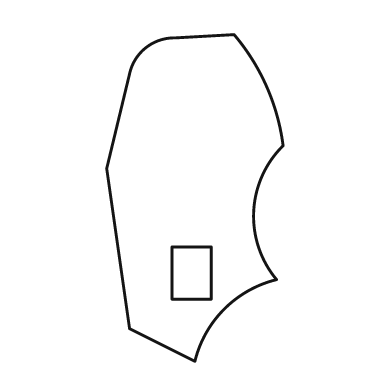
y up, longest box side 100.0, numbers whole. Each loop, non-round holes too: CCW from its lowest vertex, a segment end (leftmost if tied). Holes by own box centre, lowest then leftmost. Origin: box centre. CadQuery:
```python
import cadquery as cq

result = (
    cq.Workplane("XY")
    .moveTo(0.0, -50.0)
    .threePointArc((9.0, -34.0), (25.0, -25.0))
    .threePointArc((18.0, -4.0), (27.0, 16.0))
    .threePointArc((22.0, 34.0), (12.0, 50.0))
    .lineTo(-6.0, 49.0)
    .threePointArc((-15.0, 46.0), (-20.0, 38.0))
    .lineTo(-27.0, 9.0)
    .lineTo(-20.0, -40.0)
    .close()
    .moveTo(-7.0, -31.0)
    .lineTo(5.0, -31.0)
    .lineTo(5.0, -15.0)
    .lineTo(-7.0, -15.0)
    .close()
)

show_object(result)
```